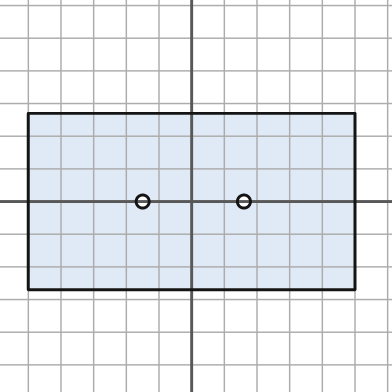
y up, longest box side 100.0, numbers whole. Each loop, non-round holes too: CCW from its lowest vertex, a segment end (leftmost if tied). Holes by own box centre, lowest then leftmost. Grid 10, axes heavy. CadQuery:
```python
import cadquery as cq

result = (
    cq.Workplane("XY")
    .moveTo(-50.0, -27.0)
    .lineTo(50.0, -27.0)
    .lineTo(50.0, 27.0)
    .lineTo(-50.0, 27.0)
    .close()
    .moveTo(-15.0, 0.0)
    .circle(2.0)
    .moveTo(16.0, 0.0)
    .circle(2.0)
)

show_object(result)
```